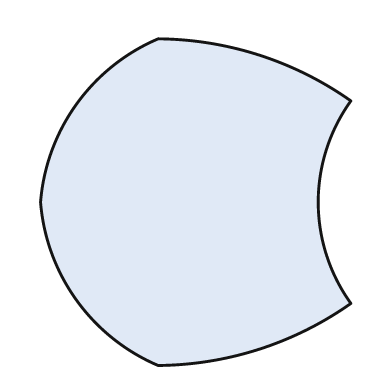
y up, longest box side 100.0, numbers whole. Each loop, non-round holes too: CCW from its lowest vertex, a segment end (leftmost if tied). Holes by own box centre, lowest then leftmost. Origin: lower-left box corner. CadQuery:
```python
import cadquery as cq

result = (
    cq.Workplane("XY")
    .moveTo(36.0, 0.0)
    .threePointArc((67.0, 5.0), (95.0, 19.0))
    .threePointArc((85.0, 50.0), (95.0, 81.0))
    .threePointArc((67.0, 95.0), (36.0, 100.0))
    .threePointArc((11.0, 80.0), (0.0, 50.0))
    .threePointArc((11.0, 20.0), (36.0, 0.0))
    .close()
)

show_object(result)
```